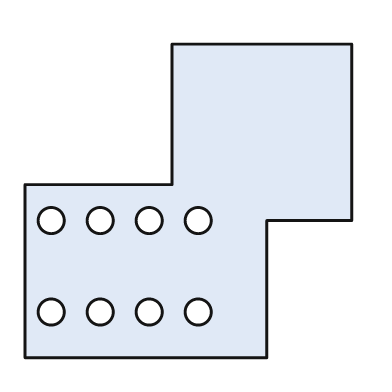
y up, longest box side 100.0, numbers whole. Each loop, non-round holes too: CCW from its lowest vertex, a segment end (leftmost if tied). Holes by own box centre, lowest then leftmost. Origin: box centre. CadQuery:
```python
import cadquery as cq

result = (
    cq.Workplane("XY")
    .moveTo(-50.0, -48.0)
    .lineTo(24.0, -48.0)
    .lineTo(24.0, -6.0)
    .lineTo(50.0, -6.0)
    .lineTo(50.0, 48.0)
    .lineTo(-5.0, 48.0)
    .lineTo(-5.0, 5.0)
    .lineTo(-50.0, 5.0)
    .close()
    .moveTo(-42.0, -34.0)
    .circle(4.0)
    .moveTo(-27.0, -34.0)
    .circle(4.0)
    .moveTo(-12.0, -34.0)
    .circle(4.0)
    .moveTo(3.0, -34.0)
    .circle(4.0)
    .moveTo(-42.0, -6.0)
    .circle(4.0)
    .moveTo(-27.0, -6.0)
    .circle(4.0)
    .moveTo(-12.0, -6.0)
    .circle(4.0)
    .moveTo(3.0, -6.0)
    .circle(4.0)
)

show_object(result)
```